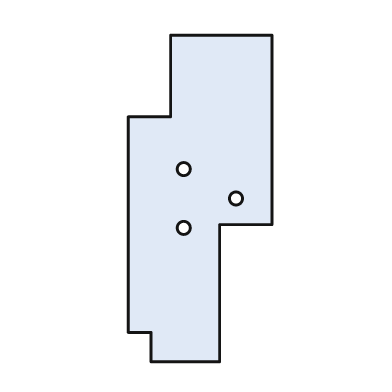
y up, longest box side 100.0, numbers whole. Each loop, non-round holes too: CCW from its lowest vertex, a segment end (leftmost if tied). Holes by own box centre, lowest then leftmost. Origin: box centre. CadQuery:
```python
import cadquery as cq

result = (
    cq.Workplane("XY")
    .moveTo(-15.0, -50.0)
    .lineTo(6.0, -50.0)
    .lineTo(6.0, -8.0)
    .lineTo(22.0, -8.0)
    .lineTo(22.0, 50.0)
    .lineTo(-9.0, 50.0)
    .lineTo(-9.0, 25.0)
    .lineTo(-22.0, 25.0)
    .lineTo(-22.0, -41.0)
    .lineTo(-15.0, -41.0)
    .close()
    .moveTo(-5.0, -9.0)
    .circle(2.0)
    .moveTo(11.0, 0.0)
    .circle(2.0)
    .moveTo(-5.0, 9.0)
    .circle(2.0)
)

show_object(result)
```